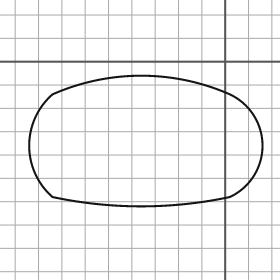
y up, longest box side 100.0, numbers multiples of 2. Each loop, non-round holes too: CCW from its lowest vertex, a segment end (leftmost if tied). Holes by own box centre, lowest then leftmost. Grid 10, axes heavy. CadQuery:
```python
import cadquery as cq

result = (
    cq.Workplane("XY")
    .moveTo(-74.0, -58.0)
    .threePointArc((-36.0, -62.0), (2.0, -58.0))
    .threePointArc((16.0, -36.0), (2.0, -14.0))
    .threePointArc((-36.0, -6.0), (-74.0, -14.0))
    .threePointArc((-84.0, -36.0), (-74.0, -58.0))
    .close()
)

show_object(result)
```